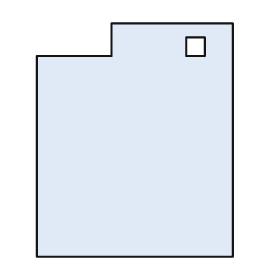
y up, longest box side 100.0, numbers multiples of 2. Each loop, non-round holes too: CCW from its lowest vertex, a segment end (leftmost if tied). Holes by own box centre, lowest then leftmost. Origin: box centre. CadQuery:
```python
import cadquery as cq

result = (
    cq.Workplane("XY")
    .moveTo(-42.0, -50.0)
    .lineTo(42.0, -50.0)
    .lineTo(42.0, 50.0)
    .lineTo(-10.0, 50.0)
    .lineTo(-10.0, 36.0)
    .lineTo(-42.0, 36.0)
    .close()
    .moveTo(22.0, 36.0)
    .lineTo(30.0, 36.0)
    .lineTo(30.0, 44.0)
    .lineTo(22.0, 44.0)
    .close()
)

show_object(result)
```